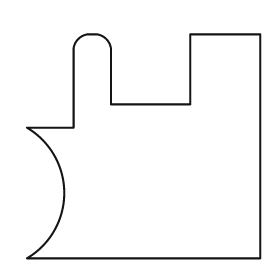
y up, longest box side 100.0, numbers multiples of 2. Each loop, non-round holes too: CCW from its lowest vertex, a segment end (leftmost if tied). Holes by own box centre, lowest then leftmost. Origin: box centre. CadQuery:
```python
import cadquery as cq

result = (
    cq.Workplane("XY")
    .moveTo(-50.0, -48.0)
    .lineTo(50.0, -48.0)
    .lineTo(50.0, 48.0)
    .lineTo(20.0, 48.0)
    .lineTo(20.0, 18.0)
    .lineTo(-14.0, 18.0)
    .lineTo(-14.0, 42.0)
    .threePointArc((-16.0, 46.0), (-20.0, 48.0))
    .lineTo(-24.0, 48.0)
    .threePointArc((-28.0, 46.0), (-30.0, 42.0))
    .lineTo(-30.0, 8.0)
    .lineTo(-50.0, 8.0)
    .threePointArc((-34.0, -20.0), (-50.0, -48.0))
    .close()
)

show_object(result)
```